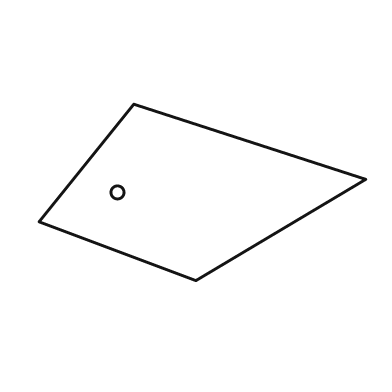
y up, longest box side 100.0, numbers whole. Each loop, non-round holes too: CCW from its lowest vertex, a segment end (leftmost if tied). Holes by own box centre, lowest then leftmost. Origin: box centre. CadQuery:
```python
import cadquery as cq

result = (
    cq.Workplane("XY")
    .moveTo(-2.0, -27.0)
    .lineTo(50.0, 4.0)
    .lineTo(-21.0, 27.0)
    .lineTo(-50.0, -9.0)
    .close()
    .moveTo(-26.0, 0.0)
    .circle(2.0)
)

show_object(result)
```